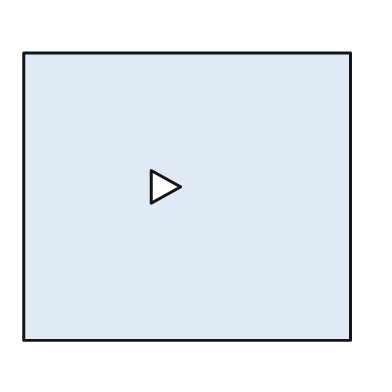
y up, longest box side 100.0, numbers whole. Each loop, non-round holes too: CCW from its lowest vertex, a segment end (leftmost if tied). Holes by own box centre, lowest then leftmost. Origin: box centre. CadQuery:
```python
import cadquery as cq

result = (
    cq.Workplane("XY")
    .moveTo(-50.0, -44.0)
    .lineTo(50.0, -44.0)
    .lineTo(50.0, 44.0)
    .lineTo(-50.0, 44.0)
    .close()
    .moveTo(-11.0, -2.0)
    .lineTo(-2.0, 3.0)
    .lineTo(-11.0, 8.0)
    .close()
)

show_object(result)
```